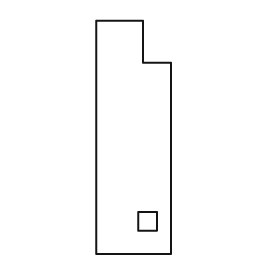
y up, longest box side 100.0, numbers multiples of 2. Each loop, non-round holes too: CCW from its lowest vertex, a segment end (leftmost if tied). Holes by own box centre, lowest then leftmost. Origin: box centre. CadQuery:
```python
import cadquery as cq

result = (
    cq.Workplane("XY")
    .moveTo(-16.0, -50.0)
    .lineTo(16.0, -50.0)
    .lineTo(16.0, 32.0)
    .lineTo(4.0, 32.0)
    .lineTo(4.0, 50.0)
    .lineTo(-16.0, 50.0)
    .close()
    .moveTo(2.0, -40.0)
    .lineTo(10.0, -40.0)
    .lineTo(10.0, -32.0)
    .lineTo(2.0, -32.0)
    .close()
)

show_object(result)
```